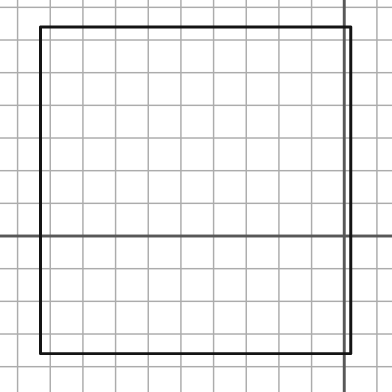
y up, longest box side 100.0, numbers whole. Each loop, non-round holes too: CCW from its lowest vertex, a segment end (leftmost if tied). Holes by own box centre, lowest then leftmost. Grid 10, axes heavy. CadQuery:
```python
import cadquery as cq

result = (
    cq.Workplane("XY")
    .moveTo(-93.0, -36.0)
    .lineTo(2.0, -36.0)
    .lineTo(2.0, 64.0)
    .lineTo(-93.0, 64.0)
    .close()
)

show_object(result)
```